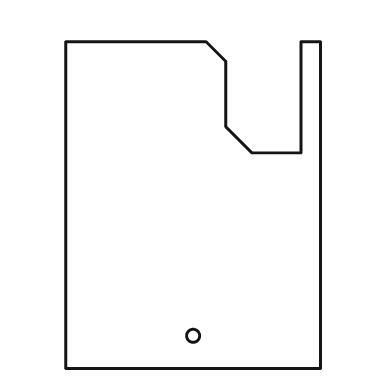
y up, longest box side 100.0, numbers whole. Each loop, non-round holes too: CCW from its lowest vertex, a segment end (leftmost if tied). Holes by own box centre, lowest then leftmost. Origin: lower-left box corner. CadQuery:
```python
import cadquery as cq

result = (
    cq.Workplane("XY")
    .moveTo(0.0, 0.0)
    .lineTo(78.0, 0.0)
    .lineTo(78.0, 100.0)
    .lineTo(72.0, 100.0)
    .lineTo(72.0, 66.0)
    .lineTo(57.0, 66.0)
    .lineTo(49.0, 74.0)
    .lineTo(49.0, 94.0)
    .lineTo(43.0, 100.0)
    .lineTo(0.0, 100.0)
    .close()
    .moveTo(39.0, 10.0)
    .circle(2.0)
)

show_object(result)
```